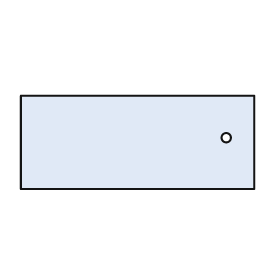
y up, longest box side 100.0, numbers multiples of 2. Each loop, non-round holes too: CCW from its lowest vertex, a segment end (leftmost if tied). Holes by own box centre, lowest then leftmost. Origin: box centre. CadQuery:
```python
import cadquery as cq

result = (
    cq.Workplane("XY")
    .moveTo(-50.0, -20.0)
    .lineTo(50.0, -20.0)
    .lineTo(50.0, 20.0)
    .lineTo(-50.0, 20.0)
    .close()
    .moveTo(38.0, 2.0)
    .circle(2.0)
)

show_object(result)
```